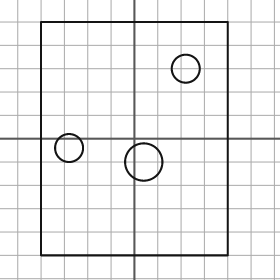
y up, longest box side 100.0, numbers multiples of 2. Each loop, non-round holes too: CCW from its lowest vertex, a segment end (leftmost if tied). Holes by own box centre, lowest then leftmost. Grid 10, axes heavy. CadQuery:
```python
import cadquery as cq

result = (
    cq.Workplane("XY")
    .moveTo(-40.0, -50.0)
    .lineTo(40.0, -50.0)
    .lineTo(40.0, 50.0)
    .lineTo(-40.0, 50.0)
    .close()
    .moveTo(4.0, -10.0)
    .circle(8.0)
    .moveTo(-28.0, -4.0)
    .circle(6.0)
    .moveTo(22.0, 30.0)
    .circle(6.0)
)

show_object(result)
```